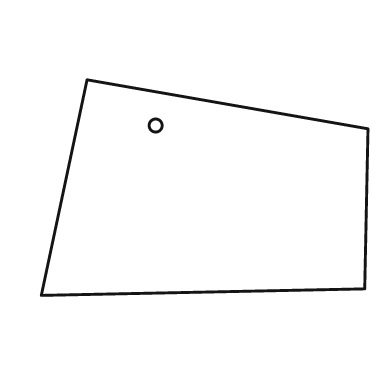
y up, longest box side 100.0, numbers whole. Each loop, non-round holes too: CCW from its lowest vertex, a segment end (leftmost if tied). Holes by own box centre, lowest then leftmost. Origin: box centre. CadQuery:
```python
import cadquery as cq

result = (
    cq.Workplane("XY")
    .moveTo(-50.0, -33.0)
    .lineTo(49.0, -31.0)
    .lineTo(50.0, 18.0)
    .lineTo(-36.0, 33.0)
    .close()
    .moveTo(-15.0, 19.0)
    .circle(2.0)
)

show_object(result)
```